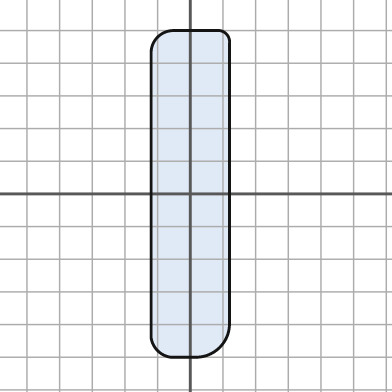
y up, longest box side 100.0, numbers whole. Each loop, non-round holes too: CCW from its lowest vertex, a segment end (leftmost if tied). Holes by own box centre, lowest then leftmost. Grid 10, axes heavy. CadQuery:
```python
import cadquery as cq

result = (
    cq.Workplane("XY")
    .moveTo(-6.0, -50.0)
    .lineTo(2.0, -50.0)
    .threePointArc((9.0, -47.0), (12.0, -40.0))
    .lineTo(12.0, 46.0)
    .threePointArc((11.0, 49.0), (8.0, 50.0))
    .lineTo(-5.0, 50.0)
    .threePointArc((-10.0, 48.0), (-12.0, 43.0))
    .lineTo(-12.0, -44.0)
    .threePointArc((-10.0, -48.0), (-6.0, -50.0))
    .close()
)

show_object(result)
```